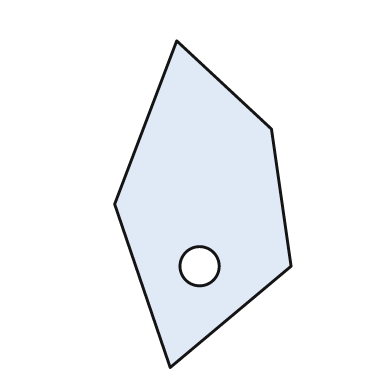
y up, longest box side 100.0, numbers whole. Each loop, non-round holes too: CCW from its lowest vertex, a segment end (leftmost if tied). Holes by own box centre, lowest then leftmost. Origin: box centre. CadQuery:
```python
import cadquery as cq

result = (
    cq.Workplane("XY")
    .moveTo(-10.0, -50.0)
    .lineTo(27.0, -19.0)
    .lineTo(21.0, 23.0)
    .lineTo(-8.0, 50.0)
    .lineTo(-27.0, 0.0)
    .close()
    .moveTo(-1.0, -19.0)
    .circle(6.0)
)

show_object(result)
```